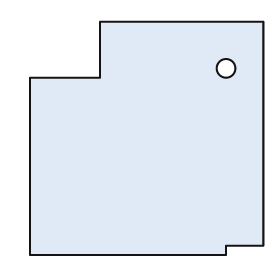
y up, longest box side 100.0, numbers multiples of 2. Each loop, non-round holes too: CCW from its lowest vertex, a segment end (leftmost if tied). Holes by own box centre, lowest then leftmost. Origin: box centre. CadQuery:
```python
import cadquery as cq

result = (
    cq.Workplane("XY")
    .moveTo(-50.0, -50.0)
    .lineTo(34.0, -50.0)
    .lineTo(34.0, -46.0)
    .lineTo(50.0, -46.0)
    .lineTo(50.0, 50.0)
    .lineTo(-20.0, 50.0)
    .lineTo(-20.0, 26.0)
    .lineTo(-50.0, 26.0)
    .close()
    .moveTo(34.0, 30.0)
    .circle(4.0)
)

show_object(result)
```